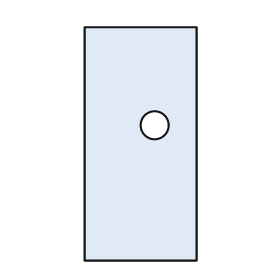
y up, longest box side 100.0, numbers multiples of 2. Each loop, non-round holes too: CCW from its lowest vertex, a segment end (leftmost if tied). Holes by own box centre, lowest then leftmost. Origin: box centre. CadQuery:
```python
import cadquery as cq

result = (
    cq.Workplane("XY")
    .moveTo(-24.0, -50.0)
    .lineTo(24.0, -50.0)
    .lineTo(24.0, 50.0)
    .lineTo(-24.0, 50.0)
    .close()
    .moveTo(6.0, 8.0)
    .circle(6.0)
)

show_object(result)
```